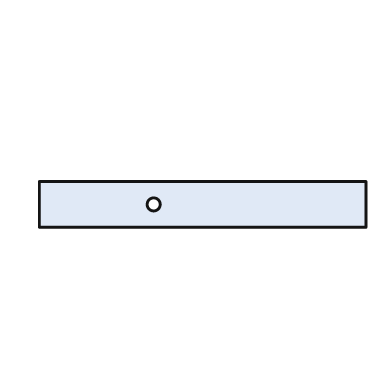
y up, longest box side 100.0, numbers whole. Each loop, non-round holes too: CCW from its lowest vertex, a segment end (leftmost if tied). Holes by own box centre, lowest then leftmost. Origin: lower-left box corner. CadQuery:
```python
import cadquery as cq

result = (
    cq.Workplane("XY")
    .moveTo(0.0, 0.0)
    .lineTo(100.0, 0.0)
    .lineTo(100.0, 14.0)
    .lineTo(0.0, 14.0)
    .close()
    .moveTo(35.0, 7.0)
    .circle(2.0)
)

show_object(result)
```